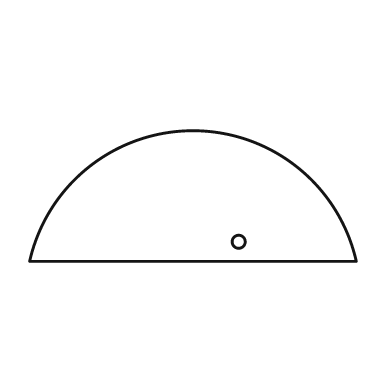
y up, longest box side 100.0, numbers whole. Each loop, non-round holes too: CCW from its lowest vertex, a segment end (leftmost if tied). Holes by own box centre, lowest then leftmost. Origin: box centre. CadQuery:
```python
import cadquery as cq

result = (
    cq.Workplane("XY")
    .moveTo(-50.0, -20.0)
    .lineTo(50.0, -20.0)
    .threePointArc((0.0, 20.0), (-50.0, -20.0))
    .close()
    .moveTo(14.0, -14.0)
    .circle(2.0)
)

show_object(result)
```